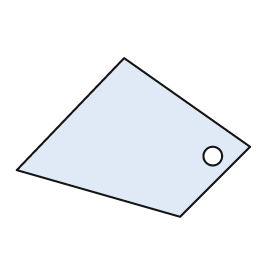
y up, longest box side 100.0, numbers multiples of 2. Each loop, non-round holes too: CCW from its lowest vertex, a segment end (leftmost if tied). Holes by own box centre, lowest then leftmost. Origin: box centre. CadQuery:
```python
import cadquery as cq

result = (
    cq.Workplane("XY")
    .moveTo(20.0, -34.0)
    .lineTo(50.0, -4.0)
    .lineTo(-4.0, 34.0)
    .lineTo(-50.0, -14.0)
    .close()
    .moveTo(34.0, -8.0)
    .circle(4.0)
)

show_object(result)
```